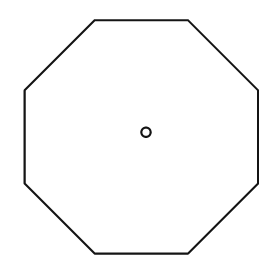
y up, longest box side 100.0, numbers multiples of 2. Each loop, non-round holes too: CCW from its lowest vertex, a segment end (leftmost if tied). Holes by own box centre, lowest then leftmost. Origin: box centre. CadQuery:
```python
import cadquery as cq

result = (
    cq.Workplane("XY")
    .moveTo(-20.0, -50.0)
    .lineTo(20.0, -50.0)
    .lineTo(50.0, -20.0)
    .lineTo(50.0, 20.0)
    .lineTo(20.0, 50.0)
    .lineTo(-20.0, 50.0)
    .lineTo(-50.0, 20.0)
    .lineTo(-50.0, -20.0)
    .close()
    .moveTo(2.0, 2.0)
    .circle(2.0)
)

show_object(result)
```